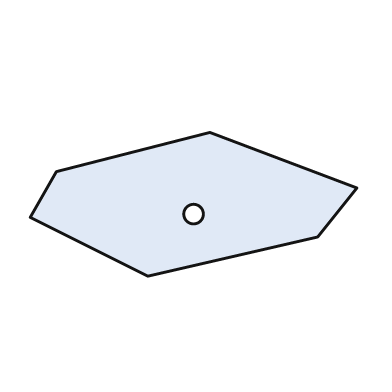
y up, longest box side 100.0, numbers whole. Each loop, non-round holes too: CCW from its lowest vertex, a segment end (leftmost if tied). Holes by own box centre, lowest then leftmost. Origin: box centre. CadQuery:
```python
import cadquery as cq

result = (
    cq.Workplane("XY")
    .moveTo(-14.0, -22.0)
    .lineTo(38.0, -10.0)
    .lineTo(50.0, 5.0)
    .lineTo(5.0, 22.0)
    .lineTo(-42.0, 10.0)
    .lineTo(-50.0, -4.0)
    .close()
    .moveTo(0.0, -3.0)
    .circle(3.0)
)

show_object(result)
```